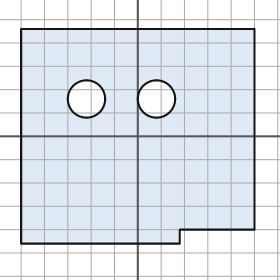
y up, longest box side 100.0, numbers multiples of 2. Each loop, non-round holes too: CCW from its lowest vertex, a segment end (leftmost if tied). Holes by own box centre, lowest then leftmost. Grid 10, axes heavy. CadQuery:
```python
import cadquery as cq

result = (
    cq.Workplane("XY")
    .moveTo(-50.0, -46.0)
    .lineTo(18.0, -46.0)
    .lineTo(18.0, -40.0)
    .lineTo(50.0, -40.0)
    .lineTo(50.0, 46.0)
    .lineTo(-50.0, 46.0)
    .close()
    .moveTo(-22.0, 16.0)
    .circle(8.0)
    .moveTo(8.0, 16.0)
    .circle(8.0)
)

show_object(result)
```